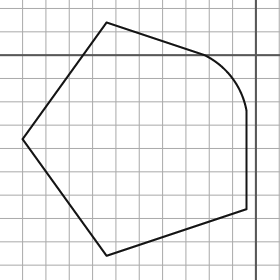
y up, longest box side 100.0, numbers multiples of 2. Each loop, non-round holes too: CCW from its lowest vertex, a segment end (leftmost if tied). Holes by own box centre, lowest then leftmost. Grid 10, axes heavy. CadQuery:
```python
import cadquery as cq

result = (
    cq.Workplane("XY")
    .moveTo(-64.0, -86.0)
    .lineTo(-4.0, -66.0)
    .lineTo(-4.0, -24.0)
    .threePointArc((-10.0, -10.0), (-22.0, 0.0))
    .lineTo(-64.0, 14.0)
    .lineTo(-100.0, -36.0)
    .close()
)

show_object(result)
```